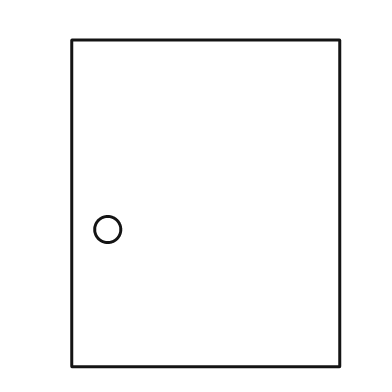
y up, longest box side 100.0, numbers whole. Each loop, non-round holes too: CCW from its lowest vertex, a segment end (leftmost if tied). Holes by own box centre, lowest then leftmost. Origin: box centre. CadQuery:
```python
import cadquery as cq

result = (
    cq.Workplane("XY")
    .moveTo(-41.0, -50.0)
    .lineTo(41.0, -50.0)
    .lineTo(41.0, 50.0)
    .lineTo(-41.0, 50.0)
    .close()
    .moveTo(-30.0, -8.0)
    .circle(4.0)
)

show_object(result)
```